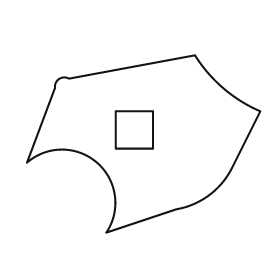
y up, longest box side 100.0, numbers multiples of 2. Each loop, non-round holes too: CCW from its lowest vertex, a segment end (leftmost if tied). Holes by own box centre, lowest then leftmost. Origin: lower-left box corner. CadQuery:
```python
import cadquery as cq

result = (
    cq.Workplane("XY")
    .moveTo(34.0, 0.0)
    .lineTo(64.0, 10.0)
    .threePointArc((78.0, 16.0), (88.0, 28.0))
    .lineTo(100.0, 52.0)
    .threePointArc((84.0, 62.0), (72.0, 76.0))
    .lineTo(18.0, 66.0)
    .threePointArc((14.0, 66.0), (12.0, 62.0))
    .lineTo(0.0, 30.0)
    .threePointArc((30.0, 30.0), (34.0, 0.0))
    .close()
    .moveTo(38.0, 36.0)
    .lineTo(54.0, 36.0)
    .lineTo(54.0, 52.0)
    .lineTo(38.0, 52.0)
    .close()
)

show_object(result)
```